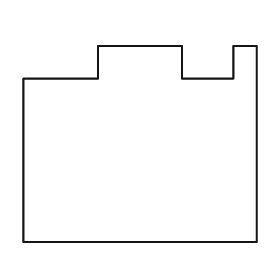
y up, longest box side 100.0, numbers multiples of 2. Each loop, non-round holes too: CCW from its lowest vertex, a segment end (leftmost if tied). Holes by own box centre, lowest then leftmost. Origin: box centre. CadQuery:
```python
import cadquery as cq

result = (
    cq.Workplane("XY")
    .moveTo(-50.0, -42.0)
    .lineTo(50.0, -42.0)
    .lineTo(50.0, 42.0)
    .lineTo(40.0, 42.0)
    .lineTo(40.0, 28.0)
    .lineTo(18.0, 28.0)
    .lineTo(18.0, 42.0)
    .lineTo(-18.0, 42.0)
    .lineTo(-18.0, 28.0)
    .lineTo(-50.0, 28.0)
    .close()
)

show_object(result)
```